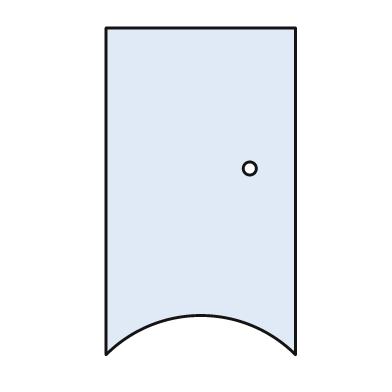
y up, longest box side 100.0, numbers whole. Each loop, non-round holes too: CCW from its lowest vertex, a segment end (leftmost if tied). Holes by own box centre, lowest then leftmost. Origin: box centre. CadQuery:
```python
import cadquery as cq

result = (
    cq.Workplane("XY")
    .moveTo(-29.0, -50.0)
    .threePointArc((0.0, -38.0), (29.0, -50.0))
    .lineTo(29.0, 50.0)
    .lineTo(-29.0, 50.0)
    .close()
    .moveTo(15.0, 7.0)
    .circle(2.0)
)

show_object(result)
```